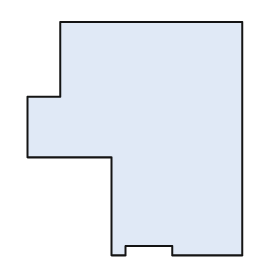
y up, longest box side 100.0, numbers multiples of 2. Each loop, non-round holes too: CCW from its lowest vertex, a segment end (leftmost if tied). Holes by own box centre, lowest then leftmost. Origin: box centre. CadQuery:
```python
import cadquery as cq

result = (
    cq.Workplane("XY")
    .moveTo(-10.0, -50.0)
    .lineTo(-4.0, -50.0)
    .lineTo(-4.0, -46.0)
    .lineTo(16.0, -46.0)
    .lineTo(16.0, -50.0)
    .lineTo(46.0, -50.0)
    .lineTo(46.0, 50.0)
    .lineTo(-32.0, 50.0)
    .lineTo(-32.0, 18.0)
    .lineTo(-46.0, 18.0)
    .lineTo(-46.0, -8.0)
    .lineTo(-10.0, -8.0)
    .close()
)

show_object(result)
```